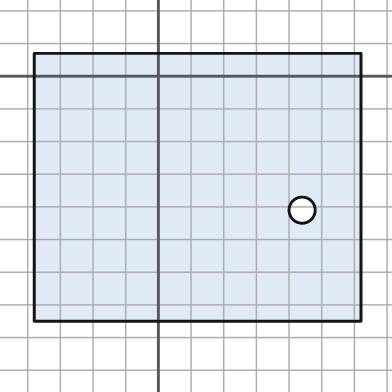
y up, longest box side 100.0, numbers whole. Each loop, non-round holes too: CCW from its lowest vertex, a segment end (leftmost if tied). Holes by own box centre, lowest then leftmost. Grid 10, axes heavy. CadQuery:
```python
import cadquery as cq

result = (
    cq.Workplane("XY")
    .moveTo(-38.0, -75.0)
    .lineTo(62.0, -75.0)
    .lineTo(62.0, 7.0)
    .lineTo(-38.0, 7.0)
    .close()
    .moveTo(44.0, -41.0)
    .circle(4.0)
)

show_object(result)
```